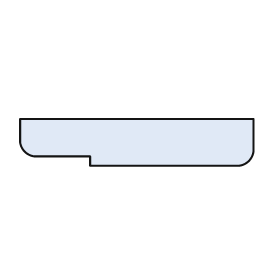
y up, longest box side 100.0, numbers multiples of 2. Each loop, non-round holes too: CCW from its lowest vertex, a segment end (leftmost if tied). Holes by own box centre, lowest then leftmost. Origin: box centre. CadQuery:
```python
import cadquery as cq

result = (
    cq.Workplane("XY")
    .moveTo(-20.0, -10.0)
    .lineTo(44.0, -10.0)
    .threePointArc((48.0, -8.0), (50.0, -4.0))
    .lineTo(50.0, 10.0)
    .lineTo(-50.0, 10.0)
    .lineTo(-50.0, 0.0)
    .threePointArc((-48.0, -4.0), (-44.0, -6.0))
    .lineTo(-20.0, -6.0)
    .close()
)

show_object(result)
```